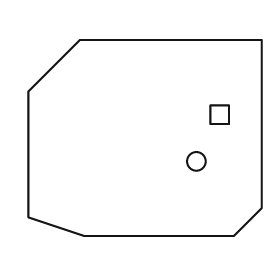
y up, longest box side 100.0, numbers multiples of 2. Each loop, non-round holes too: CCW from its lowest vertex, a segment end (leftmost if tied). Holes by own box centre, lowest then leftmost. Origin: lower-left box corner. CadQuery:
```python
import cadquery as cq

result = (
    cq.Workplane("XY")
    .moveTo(24.0, 0.0)
    .lineTo(88.0, 0.0)
    .lineTo(100.0, 12.0)
    .lineTo(100.0, 84.0)
    .lineTo(22.0, 84.0)
    .lineTo(0.0, 62.0)
    .lineTo(0.0, 8.0)
    .close()
    .moveTo(72.0, 32.0)
    .circle(4.0)
    .moveTo(78.0, 48.0)
    .lineTo(86.0, 48.0)
    .lineTo(86.0, 56.0)
    .lineTo(78.0, 56.0)
    .close()
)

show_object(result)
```